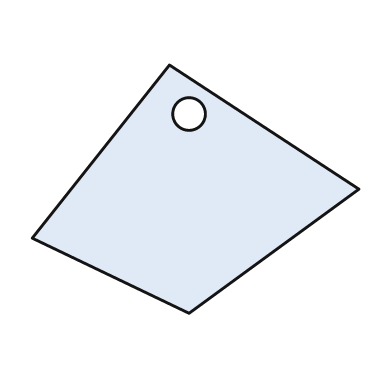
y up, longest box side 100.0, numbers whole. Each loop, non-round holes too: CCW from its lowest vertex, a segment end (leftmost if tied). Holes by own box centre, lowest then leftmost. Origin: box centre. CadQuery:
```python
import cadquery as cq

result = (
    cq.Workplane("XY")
    .moveTo(-2.0, -38.0)
    .lineTo(50.0, 0.0)
    .lineTo(-8.0, 38.0)
    .lineTo(-50.0, -15.0)
    .close()
    .moveTo(-2.0, 23.0)
    .circle(5.0)
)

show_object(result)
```